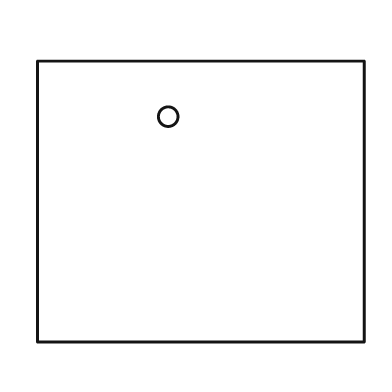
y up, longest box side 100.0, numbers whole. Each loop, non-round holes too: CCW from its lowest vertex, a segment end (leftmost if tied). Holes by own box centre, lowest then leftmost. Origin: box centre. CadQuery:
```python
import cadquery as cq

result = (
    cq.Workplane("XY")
    .moveTo(-50.0, -43.0)
    .lineTo(50.0, -43.0)
    .lineTo(50.0, 43.0)
    .lineTo(-50.0, 43.0)
    .close()
    .moveTo(-10.0, 26.0)
    .circle(3.0)
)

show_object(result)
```